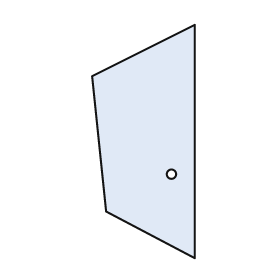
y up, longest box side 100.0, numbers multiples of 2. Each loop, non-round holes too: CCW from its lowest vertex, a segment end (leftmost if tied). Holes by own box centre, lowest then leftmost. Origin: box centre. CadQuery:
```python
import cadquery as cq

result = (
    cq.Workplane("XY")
    .moveTo(22.0, -50.0)
    .lineTo(22.0, 50.0)
    .lineTo(-22.0, 28.0)
    .lineTo(-16.0, -30.0)
    .close()
    .moveTo(12.0, -14.0)
    .circle(2.0)
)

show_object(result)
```